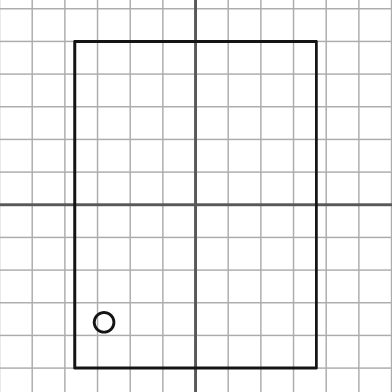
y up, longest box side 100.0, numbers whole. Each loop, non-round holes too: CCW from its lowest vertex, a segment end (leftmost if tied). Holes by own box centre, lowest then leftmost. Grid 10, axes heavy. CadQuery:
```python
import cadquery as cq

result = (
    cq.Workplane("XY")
    .moveTo(-37.0, -50.0)
    .lineTo(37.0, -50.0)
    .lineTo(37.0, 50.0)
    .lineTo(-37.0, 50.0)
    .close()
    .moveTo(-28.0, -36.0)
    .circle(3.0)
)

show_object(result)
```